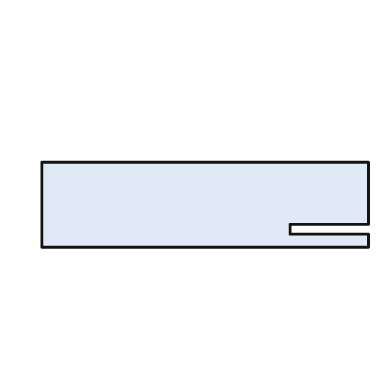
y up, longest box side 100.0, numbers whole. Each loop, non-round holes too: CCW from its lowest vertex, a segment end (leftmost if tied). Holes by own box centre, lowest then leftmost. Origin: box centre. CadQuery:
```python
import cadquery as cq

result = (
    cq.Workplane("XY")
    .moveTo(-50.0, -13.0)
    .lineTo(50.0, -13.0)
    .lineTo(50.0, -9.0)
    .lineTo(26.0, -9.0)
    .lineTo(26.0, -6.0)
    .lineTo(50.0, -6.0)
    .lineTo(50.0, 13.0)
    .lineTo(-50.0, 13.0)
    .close()
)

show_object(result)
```